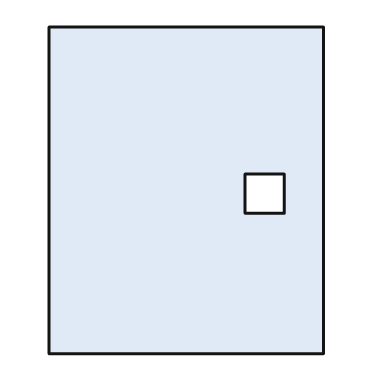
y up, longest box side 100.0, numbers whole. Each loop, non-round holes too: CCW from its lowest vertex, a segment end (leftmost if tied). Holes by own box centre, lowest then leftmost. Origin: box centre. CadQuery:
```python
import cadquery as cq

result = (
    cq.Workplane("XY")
    .moveTo(-42.0, -50.0)
    .lineTo(42.0, -50.0)
    .lineTo(42.0, 50.0)
    .lineTo(-42.0, 50.0)
    .close()
    .moveTo(18.0, -7.0)
    .lineTo(30.0, -7.0)
    .lineTo(30.0, 5.0)
    .lineTo(18.0, 5.0)
    .close()
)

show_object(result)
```